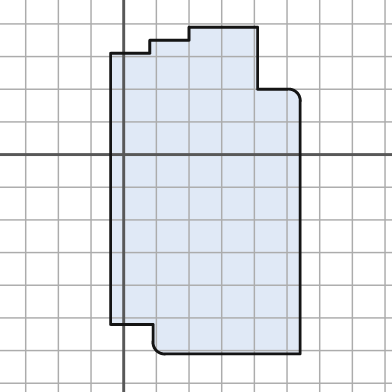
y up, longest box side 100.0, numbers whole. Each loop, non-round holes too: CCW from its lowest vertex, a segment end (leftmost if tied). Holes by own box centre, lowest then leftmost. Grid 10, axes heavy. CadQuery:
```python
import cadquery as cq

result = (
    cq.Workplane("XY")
    .moveTo(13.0, -61.0)
    .lineTo(54.0, -61.0)
    .lineTo(54.0, 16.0)
    .threePointArc((53.0, 19.0), (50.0, 20.0))
    .lineTo(41.0, 20.0)
    .lineTo(41.0, 39.0)
    .lineTo(20.0, 39.0)
    .lineTo(20.0, 35.0)
    .lineTo(8.0, 35.0)
    .lineTo(8.0, 31.0)
    .lineTo(-4.0, 31.0)
    .lineTo(-4.0, -52.0)
    .lineTo(9.0, -52.0)
    .lineTo(9.0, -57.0)
    .threePointArc((10.0, -60.0), (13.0, -61.0))
    .close()
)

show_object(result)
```